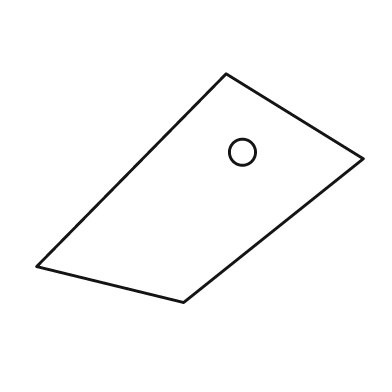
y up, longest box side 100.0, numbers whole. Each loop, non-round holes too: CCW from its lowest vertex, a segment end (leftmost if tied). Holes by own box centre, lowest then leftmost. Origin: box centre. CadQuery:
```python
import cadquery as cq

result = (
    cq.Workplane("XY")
    .moveTo(-5.0, -35.0)
    .lineTo(50.0, 9.0)
    .lineTo(8.0, 35.0)
    .lineTo(-50.0, -24.0)
    .close()
    .moveTo(13.0, 11.0)
    .circle(4.0)
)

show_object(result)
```